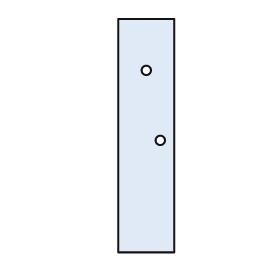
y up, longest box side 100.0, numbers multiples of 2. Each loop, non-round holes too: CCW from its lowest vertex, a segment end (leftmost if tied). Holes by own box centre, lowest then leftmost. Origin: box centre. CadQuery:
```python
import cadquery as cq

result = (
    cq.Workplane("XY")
    .moveTo(-12.0, -50.0)
    .lineTo(12.0, -50.0)
    .lineTo(12.0, 50.0)
    .lineTo(-12.0, 50.0)
    .close()
    .moveTo(6.0, -2.0)
    .circle(2.0)
    .moveTo(0.0, 28.0)
    .circle(2.0)
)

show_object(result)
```